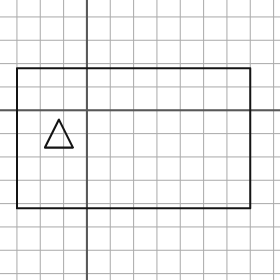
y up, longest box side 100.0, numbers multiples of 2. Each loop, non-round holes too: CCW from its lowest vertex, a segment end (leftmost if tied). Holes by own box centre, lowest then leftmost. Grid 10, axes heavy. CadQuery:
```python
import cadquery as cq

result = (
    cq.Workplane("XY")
    .moveTo(-30.0, -42.0)
    .lineTo(70.0, -42.0)
    .lineTo(70.0, 18.0)
    .lineTo(-30.0, 18.0)
    .close()
    .moveTo(-18.0, -16.0)
    .lineTo(-6.0, -16.0)
    .lineTo(-12.0, -4.0)
    .close()
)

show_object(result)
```